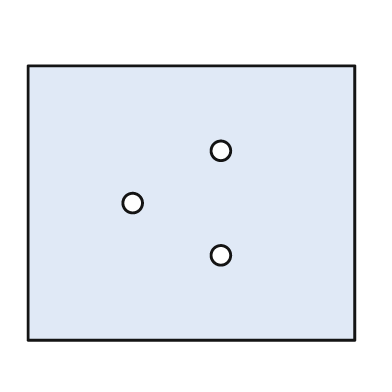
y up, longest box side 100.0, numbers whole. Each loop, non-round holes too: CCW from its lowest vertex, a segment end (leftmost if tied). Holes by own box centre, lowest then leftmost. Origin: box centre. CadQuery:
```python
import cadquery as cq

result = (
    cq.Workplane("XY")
    .moveTo(-50.0, -42.0)
    .lineTo(50.0, -42.0)
    .lineTo(50.0, 42.0)
    .lineTo(-50.0, 42.0)
    .close()
    .moveTo(9.0, -16.0)
    .circle(3.0)
    .moveTo(-18.0, 0.0)
    .circle(3.0)
    .moveTo(9.0, 16.0)
    .circle(3.0)
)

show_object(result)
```